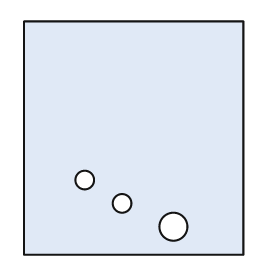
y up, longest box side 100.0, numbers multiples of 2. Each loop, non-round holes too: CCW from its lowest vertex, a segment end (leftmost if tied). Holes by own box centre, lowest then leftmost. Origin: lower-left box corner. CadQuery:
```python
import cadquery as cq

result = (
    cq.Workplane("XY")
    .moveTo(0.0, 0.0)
    .lineTo(94.0, 0.0)
    .lineTo(94.0, 100.0)
    .lineTo(0.0, 100.0)
    .close()
    .moveTo(64.0, 12.0)
    .circle(6.0)
    .moveTo(42.0, 22.0)
    .circle(4.0)
    .moveTo(26.0, 32.0)
    .circle(4.0)
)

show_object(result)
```